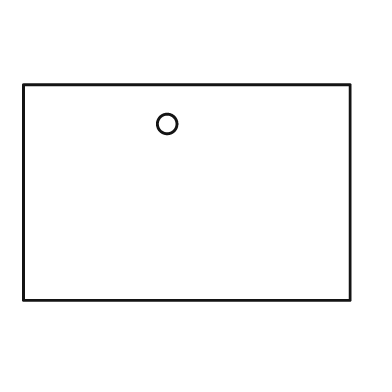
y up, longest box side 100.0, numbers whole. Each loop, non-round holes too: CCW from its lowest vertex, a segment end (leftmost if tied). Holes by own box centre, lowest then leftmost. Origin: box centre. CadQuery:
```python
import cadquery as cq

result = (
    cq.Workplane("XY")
    .moveTo(-50.0, -33.0)
    .lineTo(50.0, -33.0)
    .lineTo(50.0, 33.0)
    .lineTo(-50.0, 33.0)
    .close()
    .moveTo(-6.0, 21.0)
    .circle(3.0)
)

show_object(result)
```